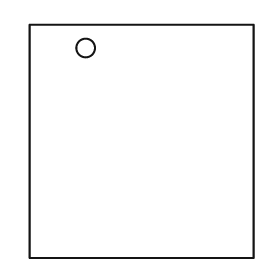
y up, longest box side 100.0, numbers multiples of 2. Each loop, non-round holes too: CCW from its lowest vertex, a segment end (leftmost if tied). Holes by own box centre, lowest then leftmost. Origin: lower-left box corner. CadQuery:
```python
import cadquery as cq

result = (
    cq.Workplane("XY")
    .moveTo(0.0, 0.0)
    .lineTo(96.0, 0.0)
    .lineTo(96.0, 100.0)
    .lineTo(0.0, 100.0)
    .close()
    .moveTo(24.0, 90.0)
    .circle(4.0)
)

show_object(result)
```